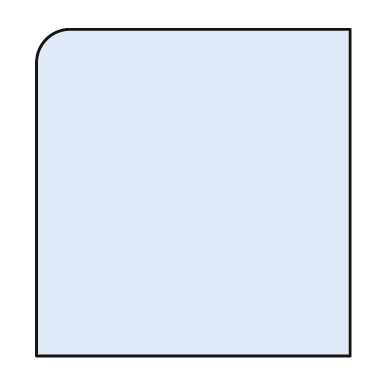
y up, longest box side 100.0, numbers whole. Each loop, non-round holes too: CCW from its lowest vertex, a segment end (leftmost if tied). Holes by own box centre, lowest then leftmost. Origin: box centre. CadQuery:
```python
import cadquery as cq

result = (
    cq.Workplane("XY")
    .moveTo(-48.0, -50.0)
    .lineTo(48.0, -50.0)
    .lineTo(48.0, 50.0)
    .lineTo(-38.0, 50.0)
    .threePointArc((-45.0, 47.0), (-48.0, 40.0))
    .close()
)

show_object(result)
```